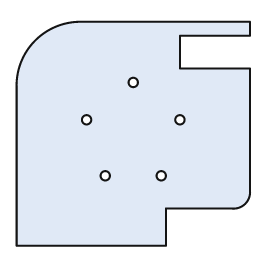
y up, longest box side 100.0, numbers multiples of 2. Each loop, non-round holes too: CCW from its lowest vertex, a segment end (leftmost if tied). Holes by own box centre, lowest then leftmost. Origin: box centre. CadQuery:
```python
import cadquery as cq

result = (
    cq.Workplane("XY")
    .moveTo(-50.0, -48.0)
    .lineTo(14.0, -48.0)
    .lineTo(14.0, -32.0)
    .lineTo(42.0, -32.0)
    .threePointArc((48.0, -30.0), (50.0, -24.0))
    .lineTo(50.0, 28.0)
    .lineTo(20.0, 28.0)
    .lineTo(20.0, 42.0)
    .lineTo(50.0, 42.0)
    .lineTo(50.0, 48.0)
    .lineTo(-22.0, 48.0)
    .threePointArc((-42.0, 40.0), (-50.0, 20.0))
    .close()
    .moveTo(-12.0, -18.0)
    .circle(2.0)
    .moveTo(12.0, -18.0)
    .circle(2.0)
    .moveTo(-20.0, 6.0)
    .circle(2.0)
    .moveTo(20.0, 6.0)
    .circle(2.0)
    .moveTo(0.0, 22.0)
    .circle(2.0)
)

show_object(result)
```